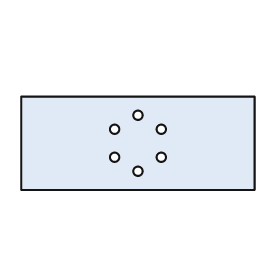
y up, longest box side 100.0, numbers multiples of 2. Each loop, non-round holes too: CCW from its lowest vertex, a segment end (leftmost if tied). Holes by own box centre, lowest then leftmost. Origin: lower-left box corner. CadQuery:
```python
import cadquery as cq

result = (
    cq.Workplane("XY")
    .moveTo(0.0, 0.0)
    .lineTo(100.0, 0.0)
    .lineTo(100.0, 40.0)
    .lineTo(0.0, 40.0)
    .close()
    .moveTo(50.0, 8.0)
    .circle(2.0)
    .moveTo(40.0, 14.0)
    .circle(2.0)
    .moveTo(60.0, 14.0)
    .circle(2.0)
    .moveTo(40.0, 26.0)
    .circle(2.0)
    .moveTo(60.0, 26.0)
    .circle(2.0)
    .moveTo(50.0, 32.0)
    .circle(2.0)
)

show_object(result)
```